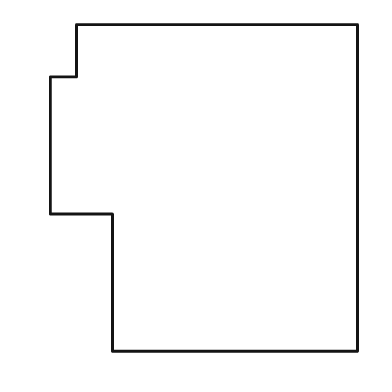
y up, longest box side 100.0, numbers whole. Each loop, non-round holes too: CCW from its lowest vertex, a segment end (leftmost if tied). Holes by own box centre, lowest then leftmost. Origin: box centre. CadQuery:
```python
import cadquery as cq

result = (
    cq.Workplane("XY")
    .moveTo(-28.0, -50.0)
    .lineTo(47.0, -50.0)
    .lineTo(47.0, 50.0)
    .lineTo(-39.0, 50.0)
    .lineTo(-39.0, 34.0)
    .lineTo(-47.0, 34.0)
    .lineTo(-47.0, -8.0)
    .lineTo(-28.0, -8.0)
    .close()
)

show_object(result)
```